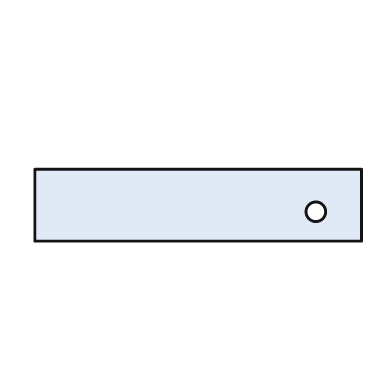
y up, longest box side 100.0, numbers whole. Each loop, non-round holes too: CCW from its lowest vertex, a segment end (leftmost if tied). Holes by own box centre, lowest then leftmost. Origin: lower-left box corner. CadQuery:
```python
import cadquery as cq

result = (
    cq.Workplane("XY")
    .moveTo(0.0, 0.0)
    .lineTo(100.0, 0.0)
    .lineTo(100.0, 22.0)
    .lineTo(0.0, 22.0)
    .close()
    .moveTo(86.0, 9.0)
    .circle(3.0)
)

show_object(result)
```